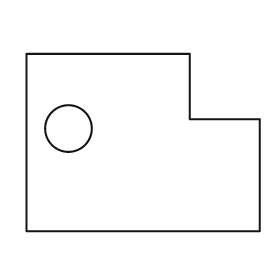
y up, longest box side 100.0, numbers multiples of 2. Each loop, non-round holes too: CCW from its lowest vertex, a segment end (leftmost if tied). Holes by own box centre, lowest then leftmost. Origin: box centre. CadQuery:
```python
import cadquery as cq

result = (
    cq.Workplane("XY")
    .moveTo(-50.0, -38.0)
    .lineTo(50.0, -38.0)
    .lineTo(50.0, 10.0)
    .lineTo(20.0, 10.0)
    .lineTo(20.0, 38.0)
    .lineTo(-50.0, 38.0)
    .close()
    .moveTo(-32.0, 6.0)
    .circle(10.0)
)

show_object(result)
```